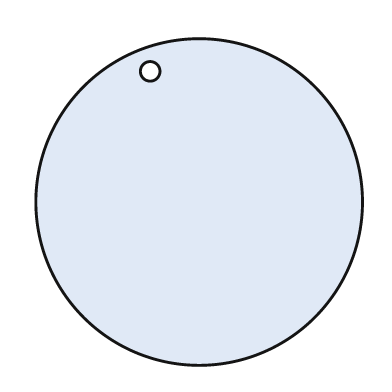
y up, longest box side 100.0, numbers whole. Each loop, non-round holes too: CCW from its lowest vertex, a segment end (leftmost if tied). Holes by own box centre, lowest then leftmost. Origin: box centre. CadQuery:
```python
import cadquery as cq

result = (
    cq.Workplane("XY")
    .moveTo(0.0, 0.0)
    .circle(50.0)
    .moveTo(-15.0, 40.0)
    .circle(3.0)
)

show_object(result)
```